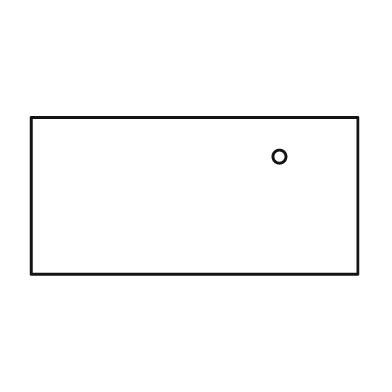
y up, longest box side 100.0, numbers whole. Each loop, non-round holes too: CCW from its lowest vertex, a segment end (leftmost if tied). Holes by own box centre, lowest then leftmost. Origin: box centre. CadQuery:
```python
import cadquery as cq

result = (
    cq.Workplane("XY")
    .moveTo(-50.0, -24.0)
    .lineTo(50.0, -24.0)
    .lineTo(50.0, 24.0)
    .lineTo(-50.0, 24.0)
    .close()
    .moveTo(26.0, 12.0)
    .circle(2.0)
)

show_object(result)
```